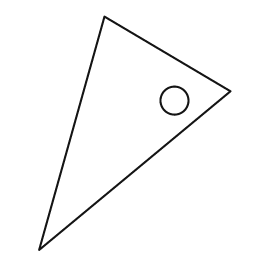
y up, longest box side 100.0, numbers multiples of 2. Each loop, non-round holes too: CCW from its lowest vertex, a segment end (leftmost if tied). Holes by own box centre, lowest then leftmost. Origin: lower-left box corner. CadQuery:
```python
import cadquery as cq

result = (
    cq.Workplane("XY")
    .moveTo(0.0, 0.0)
    .lineTo(82.0, 68.0)
    .lineTo(28.0, 100.0)
    .close()
    .moveTo(58.0, 64.0)
    .circle(6.0)
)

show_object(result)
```